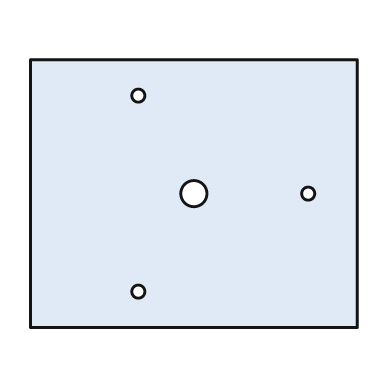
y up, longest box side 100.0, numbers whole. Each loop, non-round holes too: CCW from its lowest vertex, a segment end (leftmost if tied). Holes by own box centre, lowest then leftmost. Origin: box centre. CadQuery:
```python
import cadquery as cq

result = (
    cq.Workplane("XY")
    .moveTo(-50.0, -41.0)
    .lineTo(50.0, -41.0)
    .lineTo(50.0, 41.0)
    .lineTo(-50.0, 41.0)
    .close()
    .moveTo(-17.0, -30.0)
    .circle(2.0)
    .moveTo(0.0, 0.0)
    .circle(4.0)
    .moveTo(35.0, 0.0)
    .circle(2.0)
    .moveTo(-17.0, 30.0)
    .circle(2.0)
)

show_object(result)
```